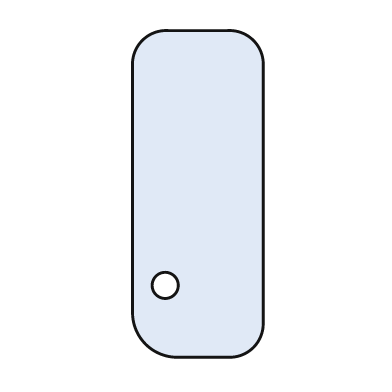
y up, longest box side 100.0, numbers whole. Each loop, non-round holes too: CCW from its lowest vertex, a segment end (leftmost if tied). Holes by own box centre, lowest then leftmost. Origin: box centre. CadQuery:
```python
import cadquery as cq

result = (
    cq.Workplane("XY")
    .moveTo(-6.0, -50.0)
    .lineTo(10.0, -50.0)
    .threePointArc((17.0, -47.0), (20.0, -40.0))
    .lineTo(20.0, 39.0)
    .threePointArc((17.0, 47.0), (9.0, 50.0))
    .lineTo(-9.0, 50.0)
    .threePointArc((-17.0, 47.0), (-20.0, 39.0))
    .lineTo(-20.0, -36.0)
    .threePointArc((-16.0, -46.0), (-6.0, -50.0))
    .close()
    .moveTo(-10.0, -28.0)
    .circle(4.0)
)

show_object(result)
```